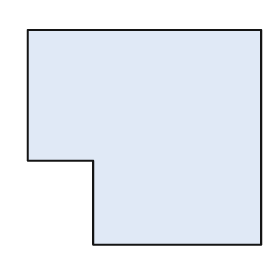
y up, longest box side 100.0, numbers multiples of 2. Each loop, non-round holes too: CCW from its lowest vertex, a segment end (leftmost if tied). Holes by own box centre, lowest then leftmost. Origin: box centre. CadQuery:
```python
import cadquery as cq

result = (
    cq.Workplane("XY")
    .moveTo(-22.0, -46.0)
    .lineTo(50.0, -46.0)
    .lineTo(50.0, 46.0)
    .lineTo(-50.0, 46.0)
    .lineTo(-50.0, -10.0)
    .lineTo(-22.0, -10.0)
    .close()
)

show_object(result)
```